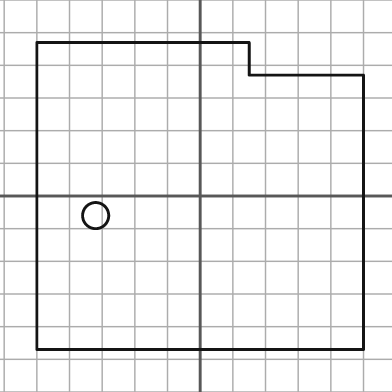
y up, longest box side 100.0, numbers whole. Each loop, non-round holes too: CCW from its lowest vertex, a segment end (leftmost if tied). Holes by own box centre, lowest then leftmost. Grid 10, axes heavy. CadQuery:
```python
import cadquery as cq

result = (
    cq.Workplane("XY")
    .moveTo(-50.0, -47.0)
    .lineTo(50.0, -47.0)
    .lineTo(50.0, 37.0)
    .lineTo(15.0, 37.0)
    .lineTo(15.0, 47.0)
    .lineTo(-50.0, 47.0)
    .close()
    .moveTo(-32.0, -6.0)
    .circle(4.0)
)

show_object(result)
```